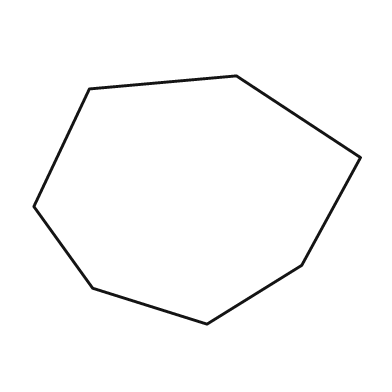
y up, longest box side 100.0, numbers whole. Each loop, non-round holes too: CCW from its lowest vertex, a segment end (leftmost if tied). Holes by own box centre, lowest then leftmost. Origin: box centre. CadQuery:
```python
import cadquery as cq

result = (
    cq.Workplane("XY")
    .moveTo(3.0, -38.0)
    .lineTo(32.0, -20.0)
    .lineTo(50.0, 13.0)
    .lineTo(12.0, 38.0)
    .lineTo(-33.0, 34.0)
    .lineTo(-50.0, -2.0)
    .lineTo(-32.0, -27.0)
    .close()
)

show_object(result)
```